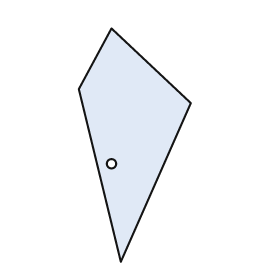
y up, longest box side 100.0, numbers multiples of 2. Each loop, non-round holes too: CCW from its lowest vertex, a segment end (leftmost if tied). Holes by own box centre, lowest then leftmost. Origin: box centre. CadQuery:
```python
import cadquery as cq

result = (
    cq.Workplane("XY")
    .moveTo(-6.0, -50.0)
    .lineTo(24.0, 18.0)
    .lineTo(-10.0, 50.0)
    .lineTo(-24.0, 24.0)
    .close()
    .moveTo(-10.0, -8.0)
    .circle(2.0)
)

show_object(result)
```